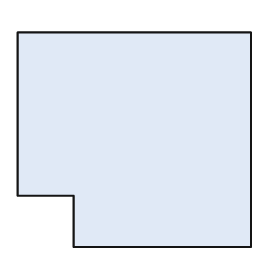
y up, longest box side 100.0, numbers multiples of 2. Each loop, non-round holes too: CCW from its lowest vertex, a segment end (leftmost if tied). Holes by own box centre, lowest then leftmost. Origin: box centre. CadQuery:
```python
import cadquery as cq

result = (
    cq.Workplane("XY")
    .moveTo(-26.0, -46.0)
    .lineTo(50.0, -46.0)
    .lineTo(50.0, 46.0)
    .lineTo(-50.0, 46.0)
    .lineTo(-50.0, -24.0)
    .lineTo(-26.0, -24.0)
    .close()
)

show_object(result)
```